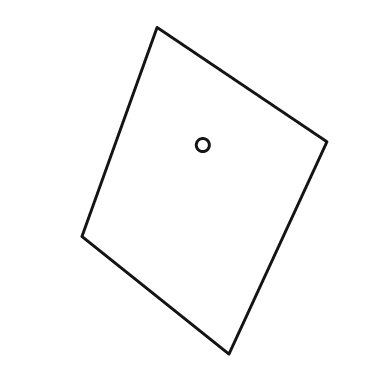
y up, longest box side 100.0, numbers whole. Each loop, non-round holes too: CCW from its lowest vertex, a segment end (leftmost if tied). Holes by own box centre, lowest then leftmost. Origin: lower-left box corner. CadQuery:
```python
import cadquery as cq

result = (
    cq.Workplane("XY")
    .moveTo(45.0, 0.0)
    .lineTo(75.0, 65.0)
    .lineTo(23.0, 100.0)
    .lineTo(0.0, 36.0)
    .close()
    .moveTo(37.0, 64.0)
    .circle(2.0)
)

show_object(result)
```